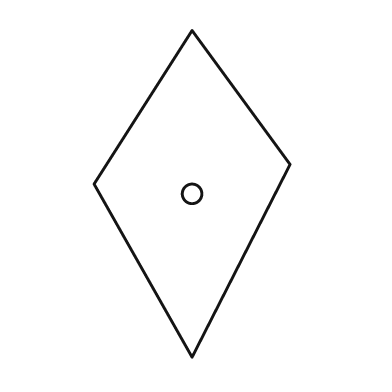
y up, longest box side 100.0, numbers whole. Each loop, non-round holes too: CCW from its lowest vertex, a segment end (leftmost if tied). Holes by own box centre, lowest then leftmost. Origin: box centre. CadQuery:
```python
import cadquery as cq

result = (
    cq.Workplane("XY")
    .moveTo(0.0, -50.0)
    .lineTo(30.0, 9.0)
    .lineTo(0.0, 50.0)
    .lineTo(-30.0, 3.0)
    .close()
    .moveTo(0.0, 0.0)
    .circle(3.0)
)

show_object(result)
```